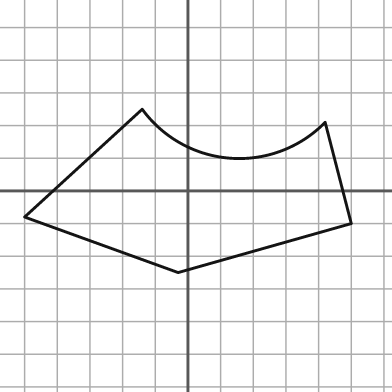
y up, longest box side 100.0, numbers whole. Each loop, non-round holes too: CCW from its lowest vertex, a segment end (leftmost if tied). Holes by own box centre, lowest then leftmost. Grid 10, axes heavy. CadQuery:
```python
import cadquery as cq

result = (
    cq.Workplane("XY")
    .moveTo(-3.0, -25.0)
    .lineTo(50.0, -10.0)
    .lineTo(42.0, 21.0)
    .threePointArc((13.0, 10.0), (-14.0, 25.0))
    .lineTo(-50.0, -8.0)
    .close()
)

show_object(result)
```